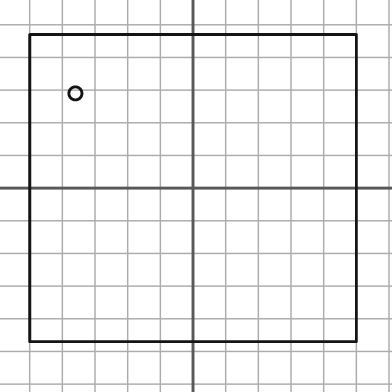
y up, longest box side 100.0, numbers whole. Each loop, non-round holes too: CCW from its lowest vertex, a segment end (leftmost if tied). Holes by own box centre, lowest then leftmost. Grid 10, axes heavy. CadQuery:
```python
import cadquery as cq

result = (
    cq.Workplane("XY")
    .moveTo(-50.0, -47.0)
    .lineTo(50.0, -47.0)
    .lineTo(50.0, 47.0)
    .lineTo(-50.0, 47.0)
    .close()
    .moveTo(-36.0, 29.0)
    .circle(2.0)
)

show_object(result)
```